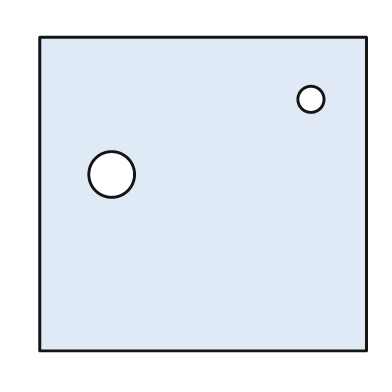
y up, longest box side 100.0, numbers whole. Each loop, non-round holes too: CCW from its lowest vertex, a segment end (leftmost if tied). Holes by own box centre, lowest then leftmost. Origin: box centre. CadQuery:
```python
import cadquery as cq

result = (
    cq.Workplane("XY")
    .moveTo(-50.0, -48.0)
    .lineTo(50.0, -48.0)
    .lineTo(50.0, 48.0)
    .lineTo(-50.0, 48.0)
    .close()
    .moveTo(-28.0, 6.0)
    .circle(7.0)
    .moveTo(33.0, 29.0)
    .circle(4.0)
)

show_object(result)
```